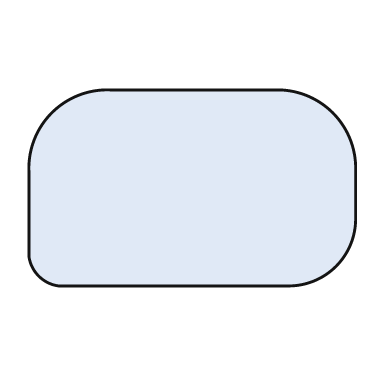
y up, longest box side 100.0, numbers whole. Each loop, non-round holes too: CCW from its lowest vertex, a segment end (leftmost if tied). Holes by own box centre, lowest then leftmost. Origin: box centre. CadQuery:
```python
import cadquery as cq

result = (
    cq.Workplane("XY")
    .moveTo(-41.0, -30.0)
    .lineTo(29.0, -30.0)
    .threePointArc((44.0, -24.0), (50.0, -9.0))
    .lineTo(50.0, 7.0)
    .threePointArc((43.0, 23.0), (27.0, 30.0))
    .lineTo(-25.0, 30.0)
    .threePointArc((-43.0, 23.0), (-50.0, 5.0))
    .lineTo(-50.0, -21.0)
    .threePointArc((-47.0, -27.0), (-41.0, -30.0))
    .close()
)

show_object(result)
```